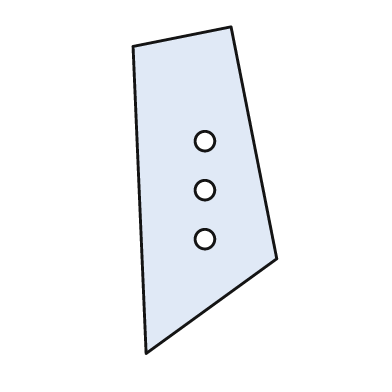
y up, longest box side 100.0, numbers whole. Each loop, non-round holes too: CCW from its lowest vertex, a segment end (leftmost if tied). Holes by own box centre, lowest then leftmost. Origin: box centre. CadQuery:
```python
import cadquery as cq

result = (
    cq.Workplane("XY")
    .moveTo(-18.0, -50.0)
    .lineTo(22.0, -21.0)
    .lineTo(8.0, 50.0)
    .lineTo(-22.0, 44.0)
    .close()
    .moveTo(0.0, -15.0)
    .circle(3.0)
    .moveTo(0.0, 0.0)
    .circle(3.0)
    .moveTo(0.0, 15.0)
    .circle(3.0)
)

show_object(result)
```